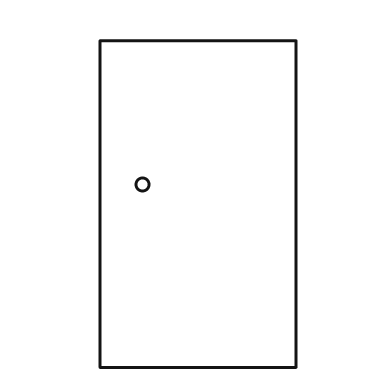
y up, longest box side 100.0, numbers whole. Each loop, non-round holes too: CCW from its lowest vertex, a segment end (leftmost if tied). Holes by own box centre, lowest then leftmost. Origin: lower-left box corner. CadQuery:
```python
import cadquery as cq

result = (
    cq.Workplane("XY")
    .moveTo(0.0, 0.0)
    .lineTo(60.0, 0.0)
    .lineTo(60.0, 100.0)
    .lineTo(0.0, 100.0)
    .close()
    .moveTo(13.0, 56.0)
    .circle(2.0)
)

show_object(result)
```